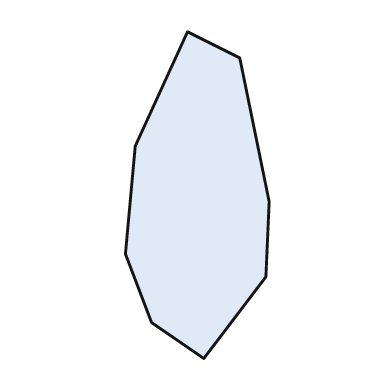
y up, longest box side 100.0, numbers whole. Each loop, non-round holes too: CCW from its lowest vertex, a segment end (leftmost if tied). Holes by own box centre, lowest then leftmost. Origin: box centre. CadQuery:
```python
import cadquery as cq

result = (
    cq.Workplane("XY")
    .moveTo(2.0, -50.0)
    .lineTo(21.0, -25.0)
    .lineTo(22.0, -2.0)
    .lineTo(13.0, 42.0)
    .lineTo(-3.0, 50.0)
    .lineTo(-19.0, 15.0)
    .lineTo(-22.0, -18.0)
    .lineTo(-14.0, -39.0)
    .close()
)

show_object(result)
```